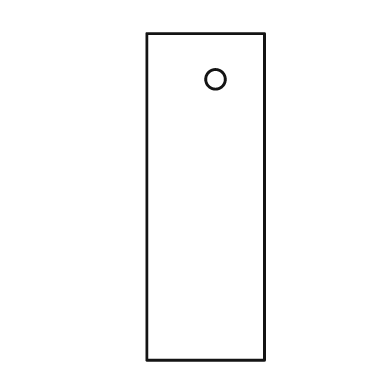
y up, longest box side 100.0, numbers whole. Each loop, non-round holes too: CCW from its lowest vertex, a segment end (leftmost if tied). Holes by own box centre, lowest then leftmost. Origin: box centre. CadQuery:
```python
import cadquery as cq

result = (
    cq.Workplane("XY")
    .moveTo(-18.0, -50.0)
    .lineTo(18.0, -50.0)
    .lineTo(18.0, 50.0)
    .lineTo(-18.0, 50.0)
    .close()
    .moveTo(3.0, 36.0)
    .circle(3.0)
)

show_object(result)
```